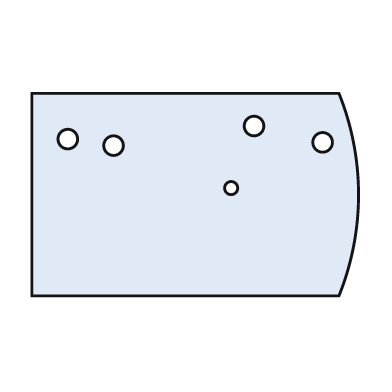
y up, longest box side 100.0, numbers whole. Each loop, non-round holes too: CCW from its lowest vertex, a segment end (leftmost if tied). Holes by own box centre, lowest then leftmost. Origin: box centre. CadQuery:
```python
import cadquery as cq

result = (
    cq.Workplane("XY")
    .moveTo(-50.0, -31.0)
    .lineTo(44.0, -31.0)
    .threePointArc((50.0, 0.0), (44.0, 31.0))
    .lineTo(-50.0, 31.0)
    .close()
    .moveTo(11.0, 2.0)
    .circle(2.0)
    .moveTo(-25.0, 15.0)
    .circle(3.0)
    .moveTo(39.0, 16.0)
    .circle(3.0)
    .moveTo(-39.0, 17.0)
    .circle(3.0)
    .moveTo(18.0, 21.0)
    .circle(3.0)
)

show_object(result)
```